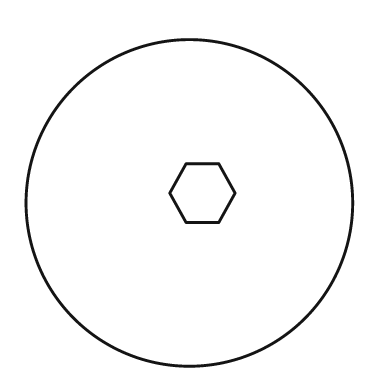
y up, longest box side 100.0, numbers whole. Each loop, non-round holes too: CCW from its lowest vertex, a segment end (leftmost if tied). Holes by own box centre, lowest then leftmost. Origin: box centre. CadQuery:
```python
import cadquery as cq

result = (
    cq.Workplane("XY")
    .moveTo(0.0, 0.0)
    .circle(50.0)
    .moveTo(-1.0, -6.0)
    .lineTo(9.0, -6.0)
    .lineTo(14.0, 3.0)
    .lineTo(9.0, 12.0)
    .lineTo(-1.0, 12.0)
    .lineTo(-6.0, 3.0)
    .close()
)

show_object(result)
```